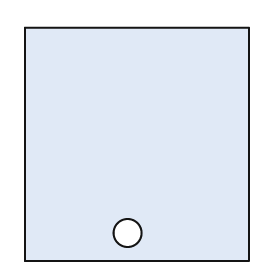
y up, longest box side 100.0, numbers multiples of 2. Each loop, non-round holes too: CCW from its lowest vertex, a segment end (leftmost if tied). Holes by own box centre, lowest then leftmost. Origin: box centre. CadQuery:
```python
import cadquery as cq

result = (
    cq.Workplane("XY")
    .moveTo(-48.0, -50.0)
    .lineTo(48.0, -50.0)
    .lineTo(48.0, 50.0)
    .lineTo(-48.0, 50.0)
    .close()
    .moveTo(-4.0, -38.0)
    .circle(6.0)
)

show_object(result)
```